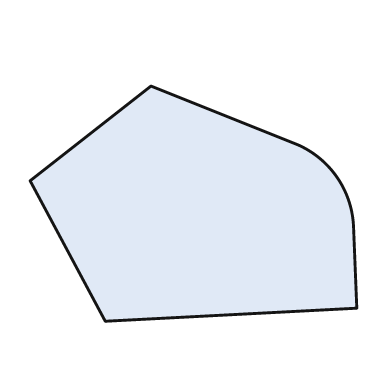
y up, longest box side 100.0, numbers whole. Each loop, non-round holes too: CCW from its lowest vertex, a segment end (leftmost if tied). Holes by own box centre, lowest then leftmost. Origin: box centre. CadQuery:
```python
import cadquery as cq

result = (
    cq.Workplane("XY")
    .moveTo(-27.0, -36.0)
    .lineTo(50.0, -32.0)
    .lineTo(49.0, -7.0)
    .threePointArc((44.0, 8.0), (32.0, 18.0))
    .lineTo(-13.0, 36.0)
    .lineTo(-50.0, 7.0)
    .close()
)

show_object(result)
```